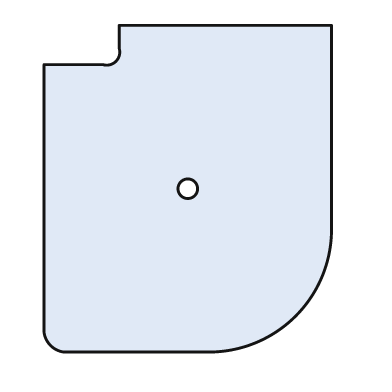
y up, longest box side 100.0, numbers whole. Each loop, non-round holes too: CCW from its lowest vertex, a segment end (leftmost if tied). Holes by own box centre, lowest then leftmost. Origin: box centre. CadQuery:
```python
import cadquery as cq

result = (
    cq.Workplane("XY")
    .moveTo(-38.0, -50.0)
    .lineTo(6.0, -50.0)
    .threePointArc((33.0, -39.0), (44.0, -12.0))
    .lineTo(44.0, 50.0)
    .lineTo(-21.0, 50.0)
    .lineTo(-21.0, 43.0)
    .threePointArc((-22.0, 39.0), (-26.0, 38.0))
    .lineTo(-44.0, 38.0)
    .lineTo(-44.0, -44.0)
    .threePointArc((-42.0, -48.0), (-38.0, -50.0))
    .close()
    .moveTo(0.0, 0.0)
    .circle(3.0)
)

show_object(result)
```